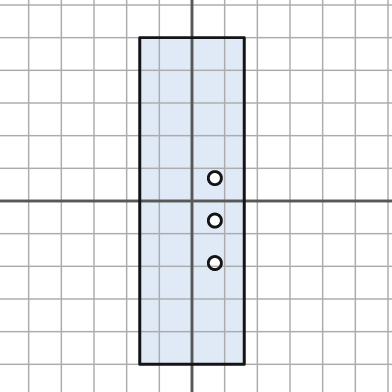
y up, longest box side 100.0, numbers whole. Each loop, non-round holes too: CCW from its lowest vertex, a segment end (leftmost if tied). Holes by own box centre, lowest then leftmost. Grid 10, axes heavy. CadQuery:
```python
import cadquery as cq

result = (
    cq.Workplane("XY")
    .moveTo(-16.0, -50.0)
    .lineTo(16.0, -50.0)
    .lineTo(16.0, 50.0)
    .lineTo(-16.0, 50.0)
    .close()
    .moveTo(7.0, -19.0)
    .circle(2.0)
    .moveTo(7.0, -6.0)
    .circle(2.0)
    .moveTo(7.0, 7.0)
    .circle(2.0)
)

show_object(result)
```